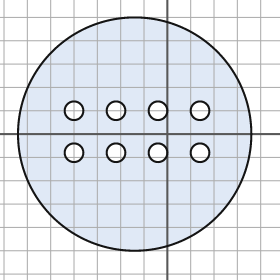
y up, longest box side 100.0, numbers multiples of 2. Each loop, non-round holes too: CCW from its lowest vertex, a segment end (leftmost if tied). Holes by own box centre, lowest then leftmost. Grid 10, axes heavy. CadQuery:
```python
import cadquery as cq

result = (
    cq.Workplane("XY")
    .moveTo(-14.0, 0.0)
    .circle(50.0)
    .moveTo(-40.0, -8.0)
    .circle(4.0)
    .moveTo(-22.0, -8.0)
    .circle(4.0)
    .moveTo(-4.0, -8.0)
    .circle(4.0)
    .moveTo(14.0, -8.0)
    .circle(4.0)
    .moveTo(-40.0, 10.0)
    .circle(4.0)
    .moveTo(-22.0, 10.0)
    .circle(4.0)
    .moveTo(-4.0, 10.0)
    .circle(4.0)
    .moveTo(14.0, 10.0)
    .circle(4.0)
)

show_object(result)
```